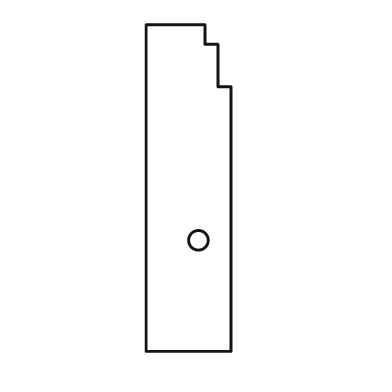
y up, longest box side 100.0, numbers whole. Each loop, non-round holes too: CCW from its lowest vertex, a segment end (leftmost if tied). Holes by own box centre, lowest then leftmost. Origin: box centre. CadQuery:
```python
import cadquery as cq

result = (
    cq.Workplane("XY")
    .moveTo(-13.0, -50.0)
    .lineTo(13.0, -50.0)
    .lineTo(13.0, 31.0)
    .lineTo(9.0, 31.0)
    .lineTo(9.0, 44.0)
    .lineTo(5.0, 44.0)
    .lineTo(5.0, 50.0)
    .lineTo(-13.0, 50.0)
    .close()
    .moveTo(3.0, -16.0)
    .circle(3.0)
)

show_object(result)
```